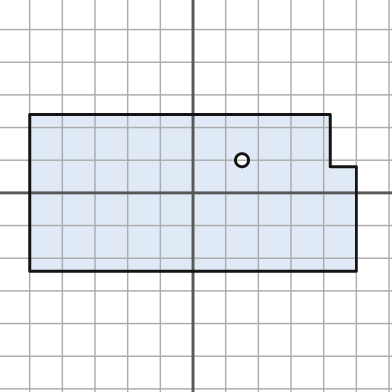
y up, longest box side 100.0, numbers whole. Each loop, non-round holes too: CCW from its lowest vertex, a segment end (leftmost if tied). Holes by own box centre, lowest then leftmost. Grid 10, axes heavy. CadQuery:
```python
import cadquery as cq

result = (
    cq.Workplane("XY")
    .moveTo(-50.0, -24.0)
    .lineTo(50.0, -24.0)
    .lineTo(50.0, 8.0)
    .lineTo(42.0, 8.0)
    .lineTo(42.0, 24.0)
    .lineTo(-50.0, 24.0)
    .close()
    .moveTo(15.0, 10.0)
    .circle(2.0)
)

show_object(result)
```